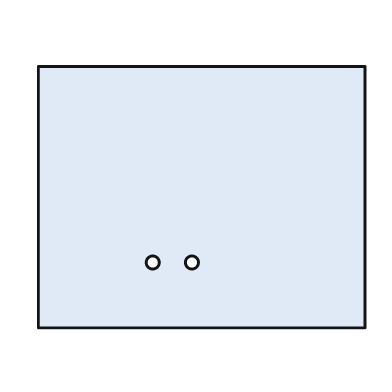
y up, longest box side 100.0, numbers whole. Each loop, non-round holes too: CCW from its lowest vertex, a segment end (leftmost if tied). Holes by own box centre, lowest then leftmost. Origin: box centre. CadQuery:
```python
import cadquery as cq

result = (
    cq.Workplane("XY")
    .moveTo(-50.0, -40.0)
    .lineTo(50.0, -40.0)
    .lineTo(50.0, 40.0)
    .lineTo(-50.0, 40.0)
    .close()
    .moveTo(-15.0, -20.0)
    .circle(2.0)
    .moveTo(-3.0, -20.0)
    .circle(2.0)
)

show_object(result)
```